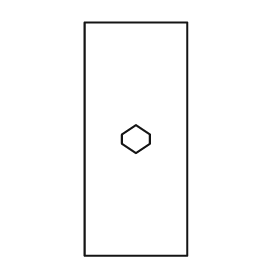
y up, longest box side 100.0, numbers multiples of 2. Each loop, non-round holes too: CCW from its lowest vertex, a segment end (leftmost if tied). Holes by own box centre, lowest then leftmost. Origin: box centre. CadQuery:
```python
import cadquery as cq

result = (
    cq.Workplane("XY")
    .moveTo(-22.0, -50.0)
    .lineTo(22.0, -50.0)
    .lineTo(22.0, 50.0)
    .lineTo(-22.0, 50.0)
    .close()
    .moveTo(0.0, -6.0)
    .lineTo(6.0, -2.0)
    .lineTo(6.0, 2.0)
    .lineTo(0.0, 6.0)
    .lineTo(-6.0, 2.0)
    .lineTo(-6.0, -2.0)
    .close()
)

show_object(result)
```